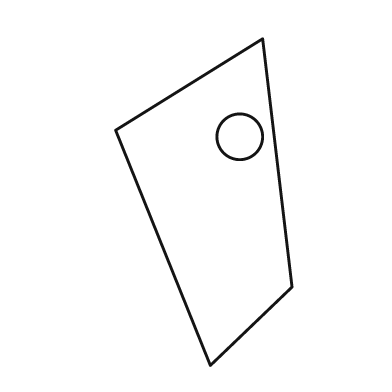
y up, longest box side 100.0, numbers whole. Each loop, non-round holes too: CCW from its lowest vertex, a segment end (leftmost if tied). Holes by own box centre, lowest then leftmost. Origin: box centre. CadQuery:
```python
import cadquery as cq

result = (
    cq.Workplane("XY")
    .moveTo(2.0, -50.0)
    .lineTo(27.0, -26.0)
    .lineTo(18.0, 50.0)
    .lineTo(-27.0, 22.0)
    .close()
    .moveTo(11.0, 20.0)
    .circle(7.0)
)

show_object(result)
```